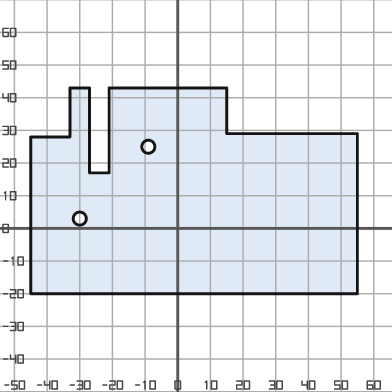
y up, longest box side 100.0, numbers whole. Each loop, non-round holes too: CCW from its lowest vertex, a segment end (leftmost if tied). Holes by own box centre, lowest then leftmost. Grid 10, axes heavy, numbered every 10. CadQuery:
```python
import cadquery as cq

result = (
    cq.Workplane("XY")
    .moveTo(-45.0, -20.0)
    .lineTo(55.0, -20.0)
    .lineTo(55.0, 29.0)
    .lineTo(15.0, 29.0)
    .lineTo(15.0, 43.0)
    .lineTo(-21.0, 43.0)
    .lineTo(-21.0, 17.0)
    .lineTo(-27.0, 17.0)
    .lineTo(-27.0, 43.0)
    .lineTo(-33.0, 43.0)
    .lineTo(-33.0, 28.0)
    .lineTo(-45.0, 28.0)
    .close()
    .moveTo(-30.0, 3.0)
    .circle(2.0)
    .moveTo(-9.0, 25.0)
    .circle(2.0)
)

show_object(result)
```